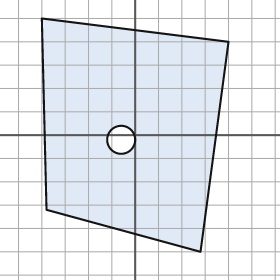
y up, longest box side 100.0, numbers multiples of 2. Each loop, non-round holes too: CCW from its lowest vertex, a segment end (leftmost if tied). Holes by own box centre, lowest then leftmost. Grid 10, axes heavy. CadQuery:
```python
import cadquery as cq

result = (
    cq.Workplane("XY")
    .moveTo(28.0, -50.0)
    .lineTo(40.0, 40.0)
    .lineTo(-40.0, 50.0)
    .lineTo(-38.0, -32.0)
    .close()
    .moveTo(-6.0, -2.0)
    .circle(6.0)
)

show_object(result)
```